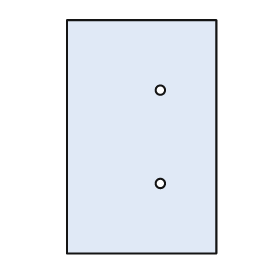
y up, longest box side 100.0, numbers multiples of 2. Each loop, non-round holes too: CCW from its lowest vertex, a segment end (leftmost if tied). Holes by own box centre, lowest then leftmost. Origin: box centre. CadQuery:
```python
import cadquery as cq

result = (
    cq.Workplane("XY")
    .moveTo(-32.0, -50.0)
    .lineTo(32.0, -50.0)
    .lineTo(32.0, 50.0)
    .lineTo(-32.0, 50.0)
    .close()
    .moveTo(8.0, -20.0)
    .circle(2.0)
    .moveTo(8.0, 20.0)
    .circle(2.0)
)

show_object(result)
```